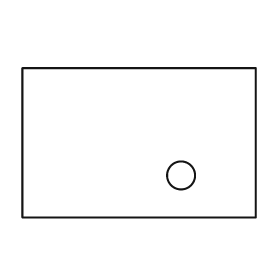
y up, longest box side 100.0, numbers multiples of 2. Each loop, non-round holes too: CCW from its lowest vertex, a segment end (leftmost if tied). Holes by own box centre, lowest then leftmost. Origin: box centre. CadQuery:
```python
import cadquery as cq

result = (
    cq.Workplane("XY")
    .moveTo(-50.0, -32.0)
    .lineTo(50.0, -32.0)
    .lineTo(50.0, 32.0)
    .lineTo(-50.0, 32.0)
    .close()
    .moveTo(18.0, -14.0)
    .circle(6.0)
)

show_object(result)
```